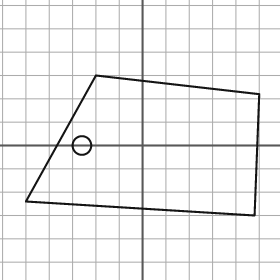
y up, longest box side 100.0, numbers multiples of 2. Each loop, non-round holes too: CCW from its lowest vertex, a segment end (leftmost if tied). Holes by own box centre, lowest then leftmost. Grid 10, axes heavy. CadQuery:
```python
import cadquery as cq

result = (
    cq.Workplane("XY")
    .moveTo(48.0, -30.0)
    .lineTo(50.0, 22.0)
    .lineTo(-20.0, 30.0)
    .lineTo(-50.0, -24.0)
    .close()
    .moveTo(-26.0, 0.0)
    .circle(4.0)
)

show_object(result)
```